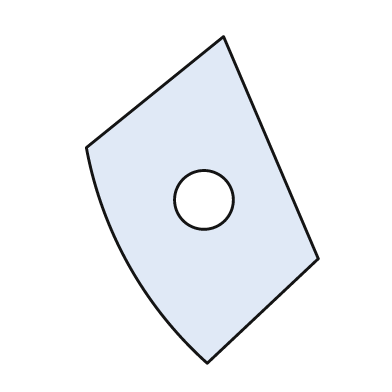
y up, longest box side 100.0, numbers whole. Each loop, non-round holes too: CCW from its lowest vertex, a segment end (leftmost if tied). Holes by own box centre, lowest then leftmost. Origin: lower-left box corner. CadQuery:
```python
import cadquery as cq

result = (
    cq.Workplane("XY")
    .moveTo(37.0, 0.0)
    .lineTo(71.0, 32.0)
    .lineTo(42.0, 100.0)
    .lineTo(0.0, 66.0)
    .threePointArc((13.0, 30.0), (37.0, 0.0))
    .close()
    .moveTo(36.0, 50.0)
    .circle(9.0)
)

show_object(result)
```